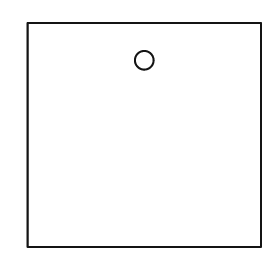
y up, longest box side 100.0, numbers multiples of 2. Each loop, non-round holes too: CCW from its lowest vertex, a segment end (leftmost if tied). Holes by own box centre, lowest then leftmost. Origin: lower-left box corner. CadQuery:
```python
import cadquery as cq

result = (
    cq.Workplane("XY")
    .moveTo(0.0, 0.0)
    .lineTo(100.0, 0.0)
    .lineTo(100.0, 96.0)
    .lineTo(0.0, 96.0)
    .close()
    .moveTo(50.0, 80.0)
    .circle(4.0)
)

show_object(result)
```